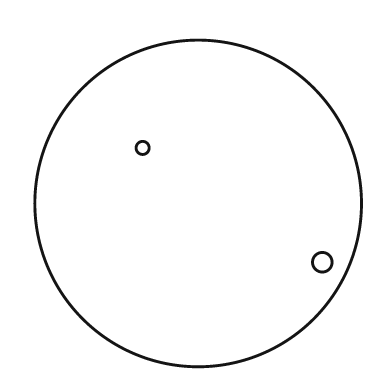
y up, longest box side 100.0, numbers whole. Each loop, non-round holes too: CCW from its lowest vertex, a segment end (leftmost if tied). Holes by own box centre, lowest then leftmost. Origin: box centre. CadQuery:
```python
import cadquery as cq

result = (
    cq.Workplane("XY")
    .moveTo(0.0, 0.0)
    .circle(50.0)
    .moveTo(38.0, -18.0)
    .circle(3.0)
    .moveTo(-17.0, 17.0)
    .circle(2.0)
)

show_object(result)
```